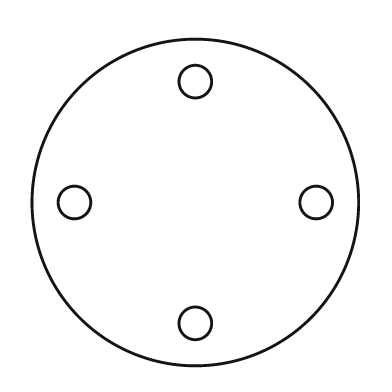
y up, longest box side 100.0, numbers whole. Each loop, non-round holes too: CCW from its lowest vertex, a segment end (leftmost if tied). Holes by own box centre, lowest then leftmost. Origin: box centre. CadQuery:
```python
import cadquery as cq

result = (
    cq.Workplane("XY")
    .moveTo(0.0, 0.0)
    .circle(50.0)
    .moveTo(0.0, -37.0)
    .circle(5.0)
    .moveTo(-37.0, 0.0)
    .circle(5.0)
    .moveTo(37.0, 0.0)
    .circle(5.0)
    .moveTo(0.0, 37.0)
    .circle(5.0)
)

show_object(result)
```